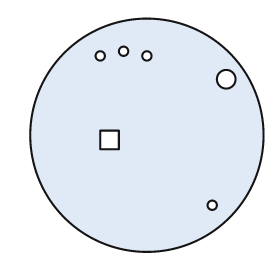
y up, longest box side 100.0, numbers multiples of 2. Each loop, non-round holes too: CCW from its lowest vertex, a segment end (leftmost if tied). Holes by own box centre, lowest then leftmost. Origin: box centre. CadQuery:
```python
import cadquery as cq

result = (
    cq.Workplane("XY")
    .moveTo(0.0, 0.0)
    .circle(50.0)
    .moveTo(28.0, -30.0)
    .circle(2.0)
    .moveTo(-20.0, -6.0)
    .lineTo(-12.0, -6.0)
    .lineTo(-12.0, 2.0)
    .lineTo(-20.0, 2.0)
    .close()
    .moveTo(34.0, 24.0)
    .circle(4.0)
    .moveTo(-20.0, 34.0)
    .circle(2.0)
    .moveTo(0.0, 34.0)
    .circle(2.0)
    .moveTo(-10.0, 36.0)
    .circle(2.0)
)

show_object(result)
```